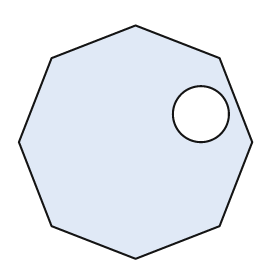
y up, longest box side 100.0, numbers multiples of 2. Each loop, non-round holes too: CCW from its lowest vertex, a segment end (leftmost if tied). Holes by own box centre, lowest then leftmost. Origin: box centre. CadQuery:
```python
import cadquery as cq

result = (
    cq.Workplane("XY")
    .moveTo(0.0, -50.0)
    .lineTo(36.0, -36.0)
    .lineTo(50.0, 0.0)
    .lineTo(36.0, 36.0)
    .lineTo(0.0, 50.0)
    .lineTo(-36.0, 36.0)
    .lineTo(-50.0, 0.0)
    .lineTo(-36.0, -36.0)
    .close()
    .moveTo(28.0, 12.0)
    .circle(12.0)
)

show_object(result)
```